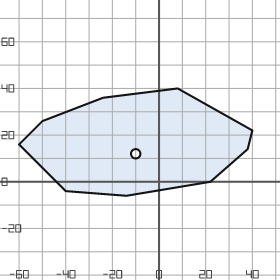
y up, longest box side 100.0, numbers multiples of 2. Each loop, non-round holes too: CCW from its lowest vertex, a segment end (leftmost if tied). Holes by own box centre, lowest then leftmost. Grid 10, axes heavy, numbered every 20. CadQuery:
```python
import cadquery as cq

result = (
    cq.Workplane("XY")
    .moveTo(-14.0, -6.0)
    .lineTo(22.0, 0.0)
    .lineTo(38.0, 14.0)
    .lineTo(40.0, 22.0)
    .lineTo(8.0, 40.0)
    .lineTo(-24.0, 36.0)
    .lineTo(-50.0, 26.0)
    .lineTo(-60.0, 16.0)
    .lineTo(-40.0, -4.0)
    .close()
    .moveTo(-10.0, 12.0)
    .circle(2.0)
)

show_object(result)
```